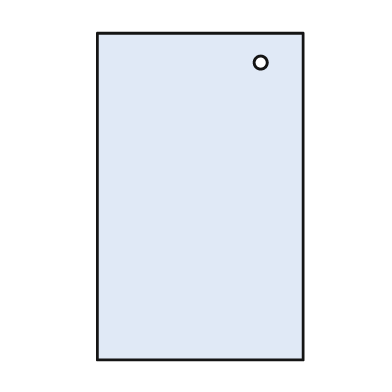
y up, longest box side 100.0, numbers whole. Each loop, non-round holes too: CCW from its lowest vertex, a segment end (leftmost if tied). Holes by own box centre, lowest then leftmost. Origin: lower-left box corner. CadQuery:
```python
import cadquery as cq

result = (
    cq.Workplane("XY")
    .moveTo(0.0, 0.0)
    .lineTo(63.0, 0.0)
    .lineTo(63.0, 100.0)
    .lineTo(0.0, 100.0)
    .close()
    .moveTo(50.0, 91.0)
    .circle(2.0)
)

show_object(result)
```